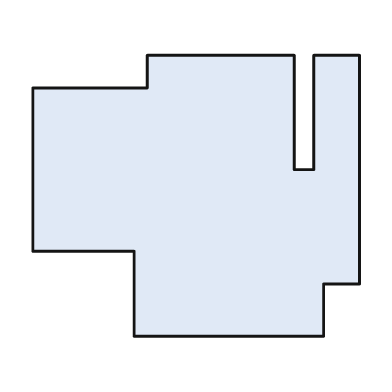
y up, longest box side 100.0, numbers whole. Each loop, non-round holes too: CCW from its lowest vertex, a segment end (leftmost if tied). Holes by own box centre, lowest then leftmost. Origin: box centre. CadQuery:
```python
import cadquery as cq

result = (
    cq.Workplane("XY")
    .moveTo(-19.0, -43.0)
    .lineTo(39.0, -43.0)
    .lineTo(39.0, -27.0)
    .lineTo(50.0, -27.0)
    .lineTo(50.0, 43.0)
    .lineTo(36.0, 43.0)
    .lineTo(36.0, 8.0)
    .lineTo(30.0, 8.0)
    .lineTo(30.0, 43.0)
    .lineTo(-15.0, 43.0)
    .lineTo(-15.0, 33.0)
    .lineTo(-50.0, 33.0)
    .lineTo(-50.0, -17.0)
    .lineTo(-19.0, -17.0)
    .close()
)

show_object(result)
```